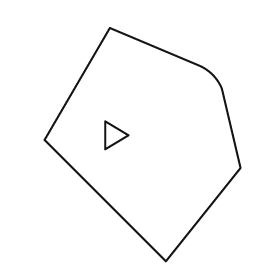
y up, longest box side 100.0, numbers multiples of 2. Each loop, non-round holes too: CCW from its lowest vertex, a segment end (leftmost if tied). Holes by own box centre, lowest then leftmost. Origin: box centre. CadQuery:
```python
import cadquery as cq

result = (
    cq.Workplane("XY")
    .moveTo(10.0, -50.0)
    .lineTo(42.0, -10.0)
    .lineTo(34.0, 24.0)
    .threePointArc((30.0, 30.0), (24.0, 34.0))
    .lineTo(-14.0, 50.0)
    .lineTo(-42.0, 2.0)
    .close()
    .moveTo(-16.0, -2.0)
    .lineTo(-6.0, 4.0)
    .lineTo(-16.0, 10.0)
    .close()
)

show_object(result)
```